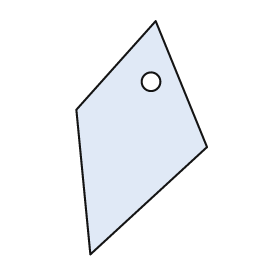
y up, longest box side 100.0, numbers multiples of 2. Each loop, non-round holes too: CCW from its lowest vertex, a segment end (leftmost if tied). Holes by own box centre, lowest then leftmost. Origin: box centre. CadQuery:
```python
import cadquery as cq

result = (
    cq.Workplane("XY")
    .moveTo(-22.0, -50.0)
    .lineTo(28.0, -4.0)
    .lineTo(6.0, 50.0)
    .lineTo(-28.0, 12.0)
    .close()
    .moveTo(4.0, 24.0)
    .circle(4.0)
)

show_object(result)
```